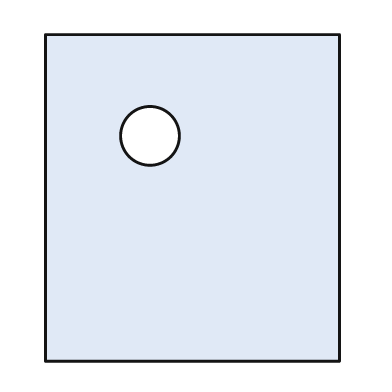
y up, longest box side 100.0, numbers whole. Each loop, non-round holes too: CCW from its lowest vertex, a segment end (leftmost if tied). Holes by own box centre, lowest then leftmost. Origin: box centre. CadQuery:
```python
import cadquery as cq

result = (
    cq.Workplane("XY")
    .moveTo(-45.0, -50.0)
    .lineTo(45.0, -50.0)
    .lineTo(45.0, 50.0)
    .lineTo(-45.0, 50.0)
    .close()
    .moveTo(-13.0, 19.0)
    .circle(9.0)
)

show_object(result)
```